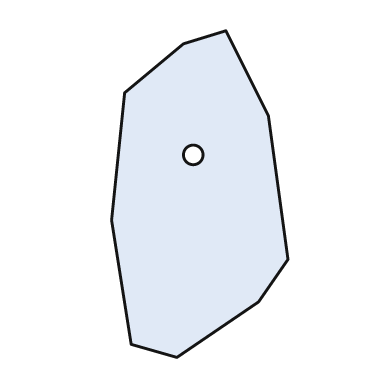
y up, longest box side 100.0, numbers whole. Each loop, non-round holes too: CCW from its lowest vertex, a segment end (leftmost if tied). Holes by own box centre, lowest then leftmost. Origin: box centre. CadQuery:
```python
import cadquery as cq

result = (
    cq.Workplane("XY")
    .moveTo(-7.0, -50.0)
    .lineTo(18.0, -33.0)
    .lineTo(27.0, -20.0)
    .lineTo(21.0, 24.0)
    .lineTo(8.0, 50.0)
    .lineTo(-5.0, 46.0)
    .lineTo(-23.0, 31.0)
    .lineTo(-27.0, -8.0)
    .lineTo(-21.0, -46.0)
    .close()
    .moveTo(-2.0, 12.0)
    .circle(3.0)
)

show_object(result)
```